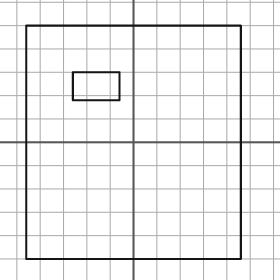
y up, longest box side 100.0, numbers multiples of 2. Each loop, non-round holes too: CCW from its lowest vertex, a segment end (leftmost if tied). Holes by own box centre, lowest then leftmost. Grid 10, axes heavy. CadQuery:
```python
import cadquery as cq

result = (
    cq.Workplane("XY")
    .moveTo(-46.0, -50.0)
    .lineTo(46.0, -50.0)
    .lineTo(46.0, 50.0)
    .lineTo(-46.0, 50.0)
    .close()
    .moveTo(-26.0, 18.0)
    .lineTo(-6.0, 18.0)
    .lineTo(-6.0, 30.0)
    .lineTo(-26.0, 30.0)
    .close()
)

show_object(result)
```